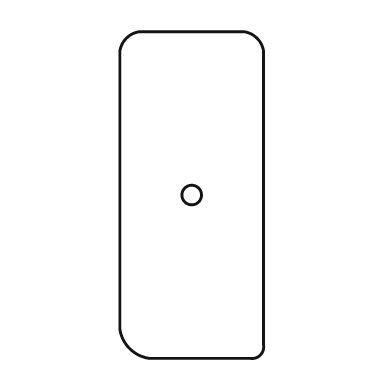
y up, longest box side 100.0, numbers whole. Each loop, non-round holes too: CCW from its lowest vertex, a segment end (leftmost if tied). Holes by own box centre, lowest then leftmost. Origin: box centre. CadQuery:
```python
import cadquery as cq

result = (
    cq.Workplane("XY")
    .moveTo(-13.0, -50.0)
    .lineTo(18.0, -50.0)
    .threePointArc((21.0, -49.0), (22.0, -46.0))
    .lineTo(22.0, 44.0)
    .threePointArc((20.0, 48.0), (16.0, 50.0))
    .lineTo(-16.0, 50.0)
    .threePointArc((-20.0, 48.0), (-22.0, 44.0))
    .lineTo(-22.0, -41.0)
    .threePointArc((-19.0, -47.0), (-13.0, -50.0))
    .close()
    .moveTo(0.0, 0.0)
    .circle(3.0)
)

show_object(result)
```